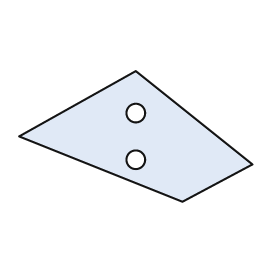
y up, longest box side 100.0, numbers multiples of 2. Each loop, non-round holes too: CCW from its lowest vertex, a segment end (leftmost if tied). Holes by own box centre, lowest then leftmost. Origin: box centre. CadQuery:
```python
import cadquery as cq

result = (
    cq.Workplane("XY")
    .moveTo(20.0, -28.0)
    .lineTo(50.0, -12.0)
    .lineTo(0.0, 28.0)
    .lineTo(-50.0, 0.0)
    .close()
    .moveTo(0.0, -10.0)
    .circle(4.0)
    .moveTo(0.0, 10.0)
    .circle(4.0)
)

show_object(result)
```